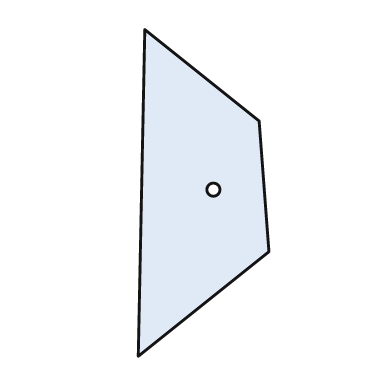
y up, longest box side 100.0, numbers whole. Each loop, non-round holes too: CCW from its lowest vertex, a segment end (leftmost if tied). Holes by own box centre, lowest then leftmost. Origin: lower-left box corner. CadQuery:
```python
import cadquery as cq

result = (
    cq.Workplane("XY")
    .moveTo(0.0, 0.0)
    .lineTo(40.0, 32.0)
    .lineTo(37.0, 72.0)
    .lineTo(2.0, 100.0)
    .close()
    .moveTo(23.0, 51.0)
    .circle(2.0)
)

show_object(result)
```